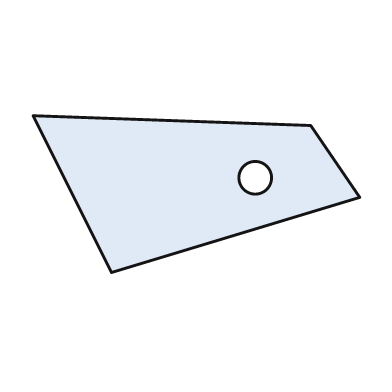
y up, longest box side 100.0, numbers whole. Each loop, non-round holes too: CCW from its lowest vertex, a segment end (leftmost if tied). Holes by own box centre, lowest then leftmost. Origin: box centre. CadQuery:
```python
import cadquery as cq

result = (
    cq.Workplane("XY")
    .moveTo(-26.0, -24.0)
    .lineTo(50.0, -1.0)
    .lineTo(35.0, 21.0)
    .lineTo(-50.0, 24.0)
    .close()
    .moveTo(18.0, 5.0)
    .circle(5.0)
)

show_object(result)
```